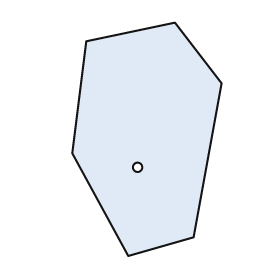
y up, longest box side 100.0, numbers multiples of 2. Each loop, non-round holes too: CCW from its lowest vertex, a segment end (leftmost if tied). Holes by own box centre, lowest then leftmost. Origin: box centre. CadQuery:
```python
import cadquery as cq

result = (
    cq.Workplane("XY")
    .moveTo(-8.0, -50.0)
    .lineTo(20.0, -42.0)
    .lineTo(32.0, 24.0)
    .lineTo(12.0, 50.0)
    .lineTo(-26.0, 42.0)
    .lineTo(-32.0, -6.0)
    .close()
    .moveTo(-4.0, -12.0)
    .circle(2.0)
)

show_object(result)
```